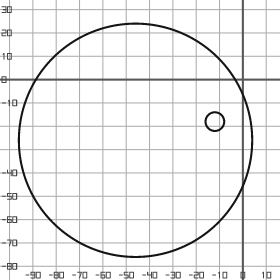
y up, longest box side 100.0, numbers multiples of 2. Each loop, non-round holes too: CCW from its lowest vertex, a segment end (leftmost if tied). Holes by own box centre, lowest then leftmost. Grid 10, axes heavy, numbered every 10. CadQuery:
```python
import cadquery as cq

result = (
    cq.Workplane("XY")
    .moveTo(-46.0, -26.0)
    .circle(50.0)
    .moveTo(-12.0, -18.0)
    .circle(4.0)
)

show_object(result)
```